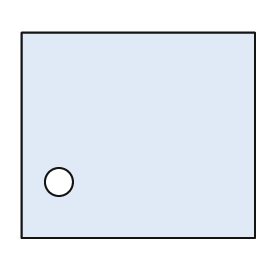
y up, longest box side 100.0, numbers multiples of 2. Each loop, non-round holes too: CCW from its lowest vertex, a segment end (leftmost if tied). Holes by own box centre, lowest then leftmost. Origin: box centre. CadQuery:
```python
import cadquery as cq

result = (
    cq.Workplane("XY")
    .moveTo(-50.0, -44.0)
    .lineTo(50.0, -44.0)
    .lineTo(50.0, 44.0)
    .lineTo(-50.0, 44.0)
    .close()
    .moveTo(-34.0, -20.0)
    .circle(6.0)
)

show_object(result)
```